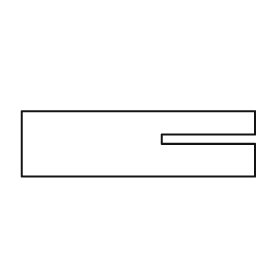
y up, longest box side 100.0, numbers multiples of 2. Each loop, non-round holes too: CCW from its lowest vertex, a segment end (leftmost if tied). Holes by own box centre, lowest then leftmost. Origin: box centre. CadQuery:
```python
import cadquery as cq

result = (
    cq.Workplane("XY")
    .moveTo(-50.0, -14.0)
    .lineTo(50.0, -14.0)
    .lineTo(50.0, 0.0)
    .lineTo(10.0, 0.0)
    .lineTo(10.0, 4.0)
    .lineTo(50.0, 4.0)
    .lineTo(50.0, 14.0)
    .lineTo(-50.0, 14.0)
    .close()
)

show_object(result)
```